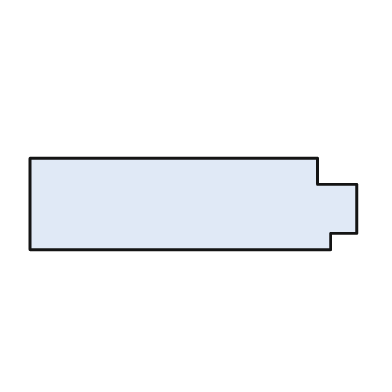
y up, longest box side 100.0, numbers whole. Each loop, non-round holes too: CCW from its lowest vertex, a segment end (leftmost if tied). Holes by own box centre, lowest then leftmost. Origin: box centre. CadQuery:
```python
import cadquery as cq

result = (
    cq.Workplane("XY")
    .moveTo(-50.0, -14.0)
    .lineTo(42.0, -14.0)
    .lineTo(42.0, -9.0)
    .lineTo(50.0, -9.0)
    .lineTo(50.0, 6.0)
    .lineTo(38.0, 6.0)
    .lineTo(38.0, 14.0)
    .lineTo(-50.0, 14.0)
    .close()
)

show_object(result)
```